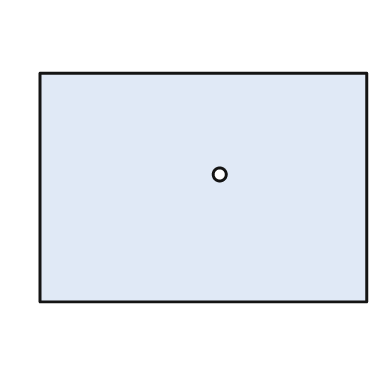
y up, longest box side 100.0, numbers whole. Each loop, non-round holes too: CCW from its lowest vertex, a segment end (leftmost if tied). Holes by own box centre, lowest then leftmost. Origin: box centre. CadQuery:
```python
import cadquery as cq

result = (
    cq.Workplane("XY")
    .moveTo(-50.0, -35.0)
    .lineTo(50.0, -35.0)
    .lineTo(50.0, 35.0)
    .lineTo(-50.0, 35.0)
    .close()
    .moveTo(5.0, 4.0)
    .circle(2.0)
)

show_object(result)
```